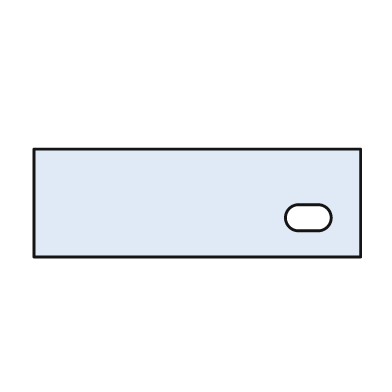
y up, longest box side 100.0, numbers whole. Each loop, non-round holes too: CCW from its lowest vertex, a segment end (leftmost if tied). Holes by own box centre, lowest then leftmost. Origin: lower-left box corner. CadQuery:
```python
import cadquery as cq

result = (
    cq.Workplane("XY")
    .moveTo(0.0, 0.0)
    .lineTo(100.0, 0.0)
    .lineTo(100.0, 33.0)
    .lineTo(0.0, 33.0)
    .close()
    .moveTo(81.0, 8.0)
    .lineTo(87.0, 8.0)
    .threePointArc((91.0, 12.0), (87.0, 16.0))
    .lineTo(81.0, 16.0)
    .threePointArc((77.0, 12.0), (81.0, 8.0))
    .close()
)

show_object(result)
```